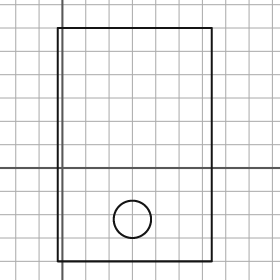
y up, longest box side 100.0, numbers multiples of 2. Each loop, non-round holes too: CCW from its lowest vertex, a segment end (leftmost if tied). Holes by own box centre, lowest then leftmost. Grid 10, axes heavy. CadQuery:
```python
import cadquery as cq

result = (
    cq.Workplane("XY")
    .moveTo(-2.0, -40.0)
    .lineTo(64.0, -40.0)
    .lineTo(64.0, 60.0)
    .lineTo(-2.0, 60.0)
    .close()
    .moveTo(30.0, -22.0)
    .circle(8.0)
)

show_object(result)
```